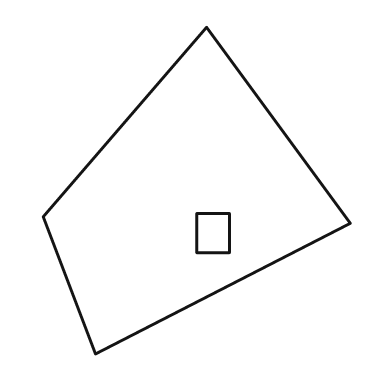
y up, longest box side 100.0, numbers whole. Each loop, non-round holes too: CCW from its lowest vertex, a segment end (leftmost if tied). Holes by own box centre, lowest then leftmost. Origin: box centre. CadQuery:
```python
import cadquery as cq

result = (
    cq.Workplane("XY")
    .moveTo(-31.0, -50.0)
    .lineTo(47.0, -10.0)
    .lineTo(3.0, 50.0)
    .lineTo(-47.0, -8.0)
    .close()
    .moveTo(0.0, -19.0)
    .lineTo(10.0, -19.0)
    .lineTo(10.0, -7.0)
    .lineTo(0.0, -7.0)
    .close()
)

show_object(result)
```